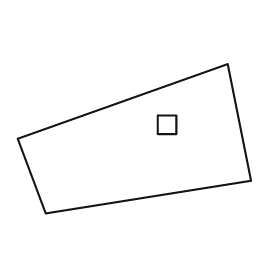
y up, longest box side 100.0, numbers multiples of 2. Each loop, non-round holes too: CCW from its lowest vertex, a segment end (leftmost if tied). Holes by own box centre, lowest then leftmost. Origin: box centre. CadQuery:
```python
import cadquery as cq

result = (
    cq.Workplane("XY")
    .moveTo(-38.0, -32.0)
    .lineTo(50.0, -18.0)
    .lineTo(40.0, 32.0)
    .lineTo(-50.0, 0.0)
    .close()
    .moveTo(10.0, 2.0)
    .lineTo(18.0, 2.0)
    .lineTo(18.0, 10.0)
    .lineTo(10.0, 10.0)
    .close()
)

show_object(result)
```